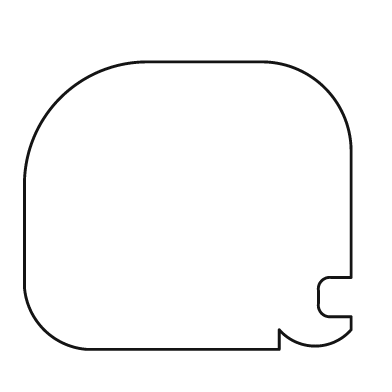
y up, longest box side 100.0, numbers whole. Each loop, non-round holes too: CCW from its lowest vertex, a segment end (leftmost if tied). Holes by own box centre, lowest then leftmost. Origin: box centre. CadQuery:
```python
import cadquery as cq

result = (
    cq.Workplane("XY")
    .moveTo(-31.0, -44.0)
    .lineTo(28.0, -44.0)
    .lineTo(28.0, -38.0)
    .threePointArc((39.0, -43.0), (50.0, -38.0))
    .lineTo(50.0, -34.0)
    .lineTo(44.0, -34.0)
    .threePointArc((41.0, -33.0), (40.0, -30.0))
    .lineTo(40.0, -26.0)
    .threePointArc((41.0, -23.0), (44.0, -22.0))
    .lineTo(50.0, -22.0)
    .lineTo(50.0, 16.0)
    .threePointArc((42.0, 36.0), (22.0, 44.0))
    .lineTo(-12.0, 44.0)
    .threePointArc((-39.0, 33.0), (-50.0, 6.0))
    .lineTo(-50.0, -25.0)
    .threePointArc((-44.0, -38.0), (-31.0, -44.0))
    .close()
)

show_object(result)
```